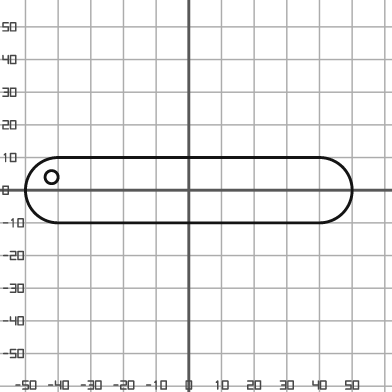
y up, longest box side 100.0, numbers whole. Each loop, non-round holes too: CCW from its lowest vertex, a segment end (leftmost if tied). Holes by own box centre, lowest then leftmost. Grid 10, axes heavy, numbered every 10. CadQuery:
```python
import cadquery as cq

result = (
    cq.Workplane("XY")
    .moveTo(-40.0, -10.0)
    .lineTo(40.0, -10.0)
    .threePointArc((50.0, 0.0), (40.0, 10.0))
    .lineTo(-40.0, 10.0)
    .threePointArc((-50.0, 0.0), (-40.0, -10.0))
    .close()
    .moveTo(-42.0, 4.0)
    .circle(2.0)
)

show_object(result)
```